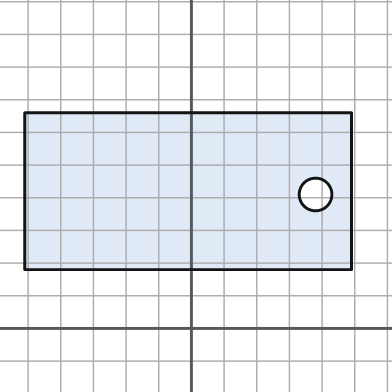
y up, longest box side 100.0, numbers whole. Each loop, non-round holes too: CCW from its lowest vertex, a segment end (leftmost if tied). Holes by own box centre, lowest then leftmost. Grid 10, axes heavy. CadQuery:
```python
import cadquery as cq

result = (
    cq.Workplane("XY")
    .moveTo(-51.0, 18.0)
    .lineTo(49.0, 18.0)
    .lineTo(49.0, 66.0)
    .lineTo(-51.0, 66.0)
    .close()
    .moveTo(38.0, 41.0)
    .circle(5.0)
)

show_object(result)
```